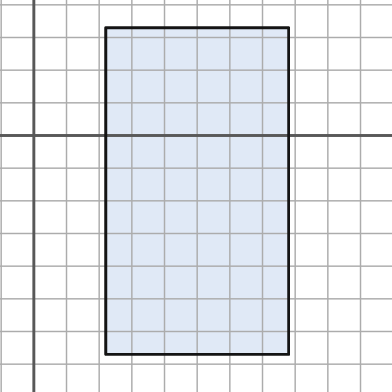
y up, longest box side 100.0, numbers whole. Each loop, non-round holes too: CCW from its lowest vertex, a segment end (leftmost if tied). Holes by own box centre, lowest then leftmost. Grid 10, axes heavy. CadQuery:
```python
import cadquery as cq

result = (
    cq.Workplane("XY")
    .moveTo(22.0, -67.0)
    .lineTo(78.0, -67.0)
    .lineTo(78.0, 33.0)
    .lineTo(22.0, 33.0)
    .close()
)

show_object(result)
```